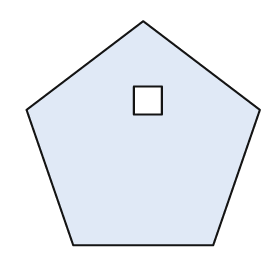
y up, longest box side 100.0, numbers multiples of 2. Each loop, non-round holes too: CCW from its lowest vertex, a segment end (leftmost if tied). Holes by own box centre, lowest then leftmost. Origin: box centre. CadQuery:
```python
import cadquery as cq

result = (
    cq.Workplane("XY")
    .moveTo(-30.0, -48.0)
    .lineTo(30.0, -48.0)
    .lineTo(50.0, 10.0)
    .lineTo(0.0, 48.0)
    .lineTo(-50.0, 10.0)
    .close()
    .moveTo(-4.0, 8.0)
    .lineTo(8.0, 8.0)
    .lineTo(8.0, 20.0)
    .lineTo(-4.0, 20.0)
    .close()
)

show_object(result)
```